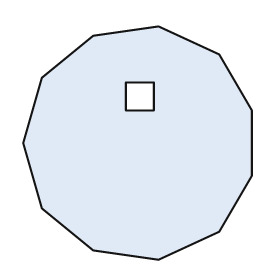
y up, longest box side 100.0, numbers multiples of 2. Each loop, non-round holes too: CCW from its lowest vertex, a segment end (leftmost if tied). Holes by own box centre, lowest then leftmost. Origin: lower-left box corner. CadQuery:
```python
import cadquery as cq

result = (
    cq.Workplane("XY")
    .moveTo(58.0, 0.0)
    .lineTo(84.0, 12.0)
    .lineTo(98.0, 36.0)
    .lineTo(98.0, 64.0)
    .lineTo(84.0, 88.0)
    .lineTo(58.0, 100.0)
    .lineTo(30.0, 96.0)
    .lineTo(8.0, 78.0)
    .lineTo(0.0, 50.0)
    .lineTo(8.0, 22.0)
    .lineTo(30.0, 4.0)
    .close()
    .moveTo(44.0, 64.0)
    .lineTo(56.0, 64.0)
    .lineTo(56.0, 76.0)
    .lineTo(44.0, 76.0)
    .close()
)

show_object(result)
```